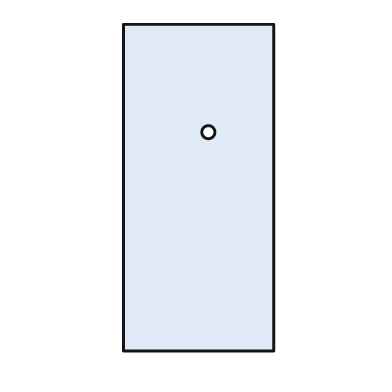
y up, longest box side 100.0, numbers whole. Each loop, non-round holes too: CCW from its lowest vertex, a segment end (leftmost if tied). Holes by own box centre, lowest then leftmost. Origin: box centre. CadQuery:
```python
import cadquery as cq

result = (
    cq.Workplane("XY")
    .moveTo(-23.0, -50.0)
    .lineTo(23.0, -50.0)
    .lineTo(23.0, 50.0)
    .lineTo(-23.0, 50.0)
    .close()
    .moveTo(3.0, 17.0)
    .circle(2.0)
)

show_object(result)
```